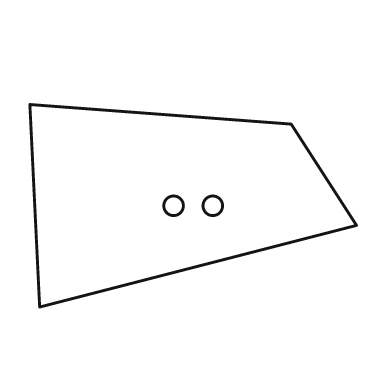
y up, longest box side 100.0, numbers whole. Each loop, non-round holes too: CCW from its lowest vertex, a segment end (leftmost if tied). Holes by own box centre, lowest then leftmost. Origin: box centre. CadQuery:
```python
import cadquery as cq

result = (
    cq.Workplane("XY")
    .moveTo(-47.0, -31.0)
    .lineTo(50.0, -6.0)
    .lineTo(30.0, 25.0)
    .lineTo(-50.0, 31.0)
    .close()
    .moveTo(-6.0, 0.0)
    .circle(3.0)
    .moveTo(6.0, 0.0)
    .circle(3.0)
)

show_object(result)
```